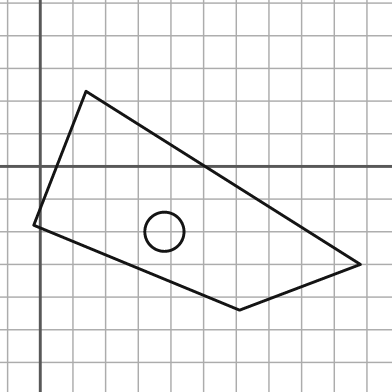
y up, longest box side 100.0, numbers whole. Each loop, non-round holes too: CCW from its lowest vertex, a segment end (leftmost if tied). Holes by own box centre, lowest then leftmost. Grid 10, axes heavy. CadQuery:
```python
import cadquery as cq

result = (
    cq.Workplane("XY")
    .moveTo(61.0, -44.0)
    .lineTo(98.0, -30.0)
    .lineTo(14.0, 23.0)
    .lineTo(-2.0, -18.0)
    .close()
    .moveTo(38.0, -20.0)
    .circle(6.0)
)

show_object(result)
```